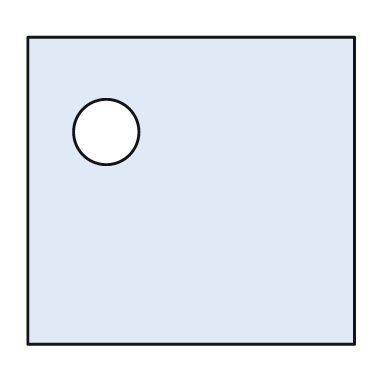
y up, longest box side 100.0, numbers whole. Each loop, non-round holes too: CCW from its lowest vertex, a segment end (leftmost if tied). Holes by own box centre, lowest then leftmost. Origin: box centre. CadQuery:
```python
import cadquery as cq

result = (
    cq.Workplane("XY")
    .moveTo(-50.0, -47.0)
    .lineTo(50.0, -47.0)
    .lineTo(50.0, 47.0)
    .lineTo(-50.0, 47.0)
    .close()
    .moveTo(-26.0, 18.0)
    .circle(10.0)
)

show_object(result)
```